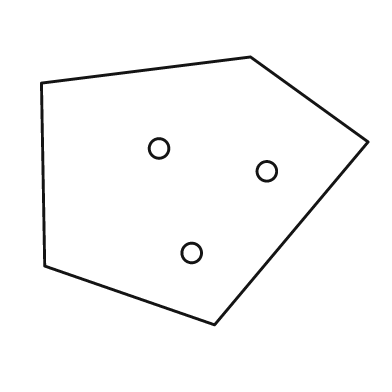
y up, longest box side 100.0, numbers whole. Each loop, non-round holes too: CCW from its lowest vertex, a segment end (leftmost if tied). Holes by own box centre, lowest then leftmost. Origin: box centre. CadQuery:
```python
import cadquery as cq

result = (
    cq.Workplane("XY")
    .moveTo(3.0, -41.0)
    .lineTo(50.0, 15.0)
    .lineTo(14.0, 41.0)
    .lineTo(-50.0, 33.0)
    .lineTo(-49.0, -23.0)
    .close()
    .moveTo(-4.0, -19.0)
    .circle(3.0)
    .moveTo(19.0, 6.0)
    .circle(3.0)
    .moveTo(-14.0, 13.0)
    .circle(3.0)
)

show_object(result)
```